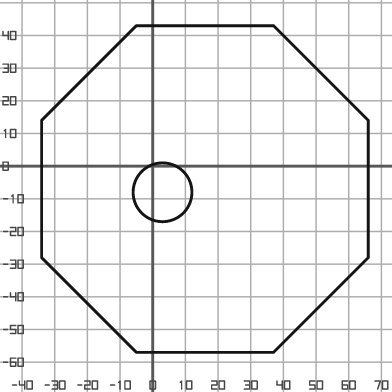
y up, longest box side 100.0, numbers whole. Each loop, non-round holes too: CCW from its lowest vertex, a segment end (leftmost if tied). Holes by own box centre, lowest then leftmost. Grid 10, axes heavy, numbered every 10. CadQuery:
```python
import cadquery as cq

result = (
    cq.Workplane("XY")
    .moveTo(-5.0, -57.0)
    .lineTo(37.0, -57.0)
    .lineTo(66.0, -28.0)
    .lineTo(66.0, 14.0)
    .lineTo(37.0, 43.0)
    .lineTo(-5.0, 43.0)
    .lineTo(-34.0, 14.0)
    .lineTo(-34.0, -28.0)
    .close()
    .moveTo(3.0, -8.0)
    .circle(9.0)
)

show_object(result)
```